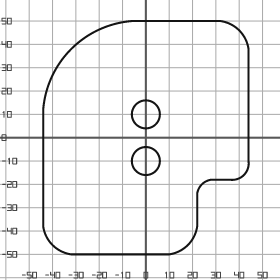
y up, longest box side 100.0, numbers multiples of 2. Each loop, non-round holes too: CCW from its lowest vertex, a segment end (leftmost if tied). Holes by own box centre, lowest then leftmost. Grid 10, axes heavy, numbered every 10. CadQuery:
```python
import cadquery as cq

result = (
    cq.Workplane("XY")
    .moveTo(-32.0, -50.0)
    .lineTo(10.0, -50.0)
    .threePointArc((18.0, -46.0), (22.0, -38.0))
    .lineTo(22.0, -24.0)
    .threePointArc((24.0, -20.0), (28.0, -18.0))
    .lineTo(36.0, -18.0)
    .threePointArc((42.0, -16.0), (44.0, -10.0))
    .lineTo(44.0, 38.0)
    .threePointArc((40.0, 46.0), (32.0, 50.0))
    .lineTo(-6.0, 50.0)
    .threePointArc((-32.0, 38.0), (-44.0, 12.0))
    .lineTo(-44.0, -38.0)
    .threePointArc((-40.0, -46.0), (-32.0, -50.0))
    .close()
    .moveTo(0.0, -10.0)
    .circle(6.0)
    .moveTo(0.0, 10.0)
    .circle(6.0)
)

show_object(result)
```